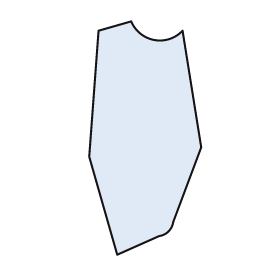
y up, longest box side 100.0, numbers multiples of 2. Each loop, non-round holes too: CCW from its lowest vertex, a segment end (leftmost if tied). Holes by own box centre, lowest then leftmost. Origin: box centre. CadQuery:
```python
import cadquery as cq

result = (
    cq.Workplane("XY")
    .moveTo(-12.0, -50.0)
    .lineTo(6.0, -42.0)
    .threePointArc((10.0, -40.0), (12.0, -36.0))
    .lineTo(24.0, -4.0)
    .lineTo(16.0, 46.0)
    .threePointArc((4.0, 42.0), (-6.0, 50.0))
    .lineTo(-20.0, 46.0)
    .lineTo(-24.0, -8.0)
    .close()
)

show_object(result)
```